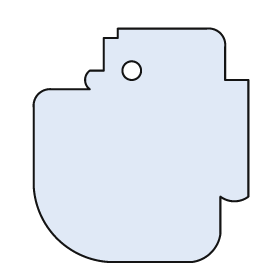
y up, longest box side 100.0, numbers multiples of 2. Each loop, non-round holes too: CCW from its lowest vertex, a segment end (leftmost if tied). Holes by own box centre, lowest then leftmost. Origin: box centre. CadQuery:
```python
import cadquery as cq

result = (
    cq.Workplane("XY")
    .moveTo(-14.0, -50.0)
    .lineTo(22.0, -50.0)
    .threePointArc((30.0, -46.0), (34.0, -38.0))
    .lineTo(34.0, -22.0)
    .threePointArc((40.0, -24.0), (46.0, -22.0))
    .lineTo(46.0, 28.0)
    .lineTo(36.0, 28.0)
    .lineTo(36.0, 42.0)
    .threePointArc((34.0, 48.0), (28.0, 50.0))
    .lineTo(-10.0, 50.0)
    .lineTo(-10.0, 46.0)
    .lineTo(-16.0, 46.0)
    .lineTo(-16.0, 32.0)
    .lineTo(-22.0, 32.0)
    .threePointArc((-24.0, 28.0), (-22.0, 24.0))
    .lineTo(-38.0, 24.0)
    .threePointArc((-44.0, 22.0), (-46.0, 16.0))
    .lineTo(-46.0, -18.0)
    .threePointArc((-36.0, -40.0), (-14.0, -50.0))
    .close()
    .moveTo(-4.0, 32.0)
    .circle(4.0)
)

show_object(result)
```